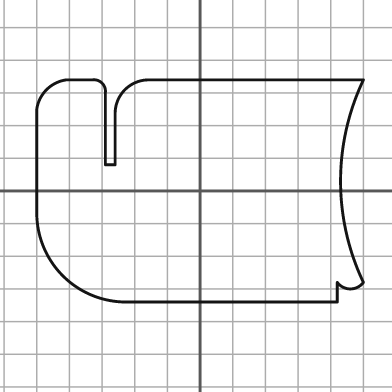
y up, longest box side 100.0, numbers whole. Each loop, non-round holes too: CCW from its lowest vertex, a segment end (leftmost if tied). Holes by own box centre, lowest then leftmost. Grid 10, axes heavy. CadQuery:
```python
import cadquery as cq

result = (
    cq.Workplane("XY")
    .moveTo(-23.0, -34.0)
    .lineTo(42.0, -34.0)
    .lineTo(42.0, -28.0)
    .threePointArc((46.0, -30.0), (50.0, -28.0))
    .threePointArc((43.0, 3.0), (50.0, 34.0))
    .lineTo(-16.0, 34.0)
    .threePointArc((-23.0, 31.0), (-26.0, 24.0))
    .lineTo(-26.0, 8.0)
    .lineTo(-29.0, 8.0)
    .lineTo(-29.0, 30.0)
    .threePointArc((-30.0, 33.0), (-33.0, 34.0))
    .lineTo(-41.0, 34.0)
    .threePointArc((-47.0, 31.0), (-50.0, 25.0))
    .lineTo(-50.0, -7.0)
    .threePointArc((-42.0, -26.0), (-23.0, -34.0))
    .close()
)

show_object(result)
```